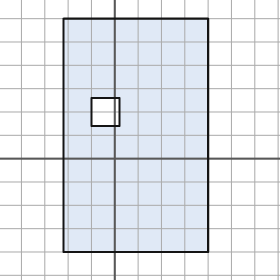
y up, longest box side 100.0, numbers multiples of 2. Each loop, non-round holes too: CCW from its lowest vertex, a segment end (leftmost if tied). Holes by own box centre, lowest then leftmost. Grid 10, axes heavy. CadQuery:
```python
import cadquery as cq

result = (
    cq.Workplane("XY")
    .moveTo(-22.0, -40.0)
    .lineTo(40.0, -40.0)
    .lineTo(40.0, 60.0)
    .lineTo(-22.0, 60.0)
    .close()
    .moveTo(-10.0, 14.0)
    .lineTo(2.0, 14.0)
    .lineTo(2.0, 26.0)
    .lineTo(-10.0, 26.0)
    .close()
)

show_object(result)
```